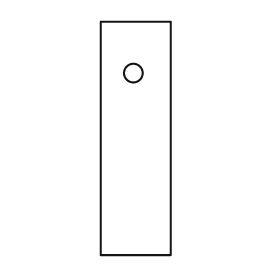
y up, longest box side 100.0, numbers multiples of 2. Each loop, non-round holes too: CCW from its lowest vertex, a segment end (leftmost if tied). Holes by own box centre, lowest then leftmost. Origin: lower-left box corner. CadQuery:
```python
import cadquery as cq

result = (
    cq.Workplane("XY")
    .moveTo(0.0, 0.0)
    .lineTo(30.0, 0.0)
    .lineTo(30.0, 100.0)
    .lineTo(0.0, 100.0)
    .close()
    .moveTo(14.0, 78.0)
    .circle(4.0)
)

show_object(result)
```